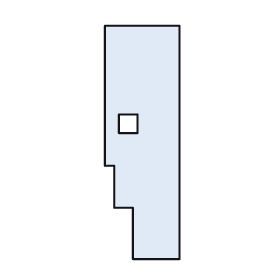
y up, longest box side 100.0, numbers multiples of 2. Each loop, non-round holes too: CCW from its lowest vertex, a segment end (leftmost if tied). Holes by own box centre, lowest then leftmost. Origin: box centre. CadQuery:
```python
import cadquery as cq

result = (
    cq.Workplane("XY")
    .moveTo(-4.0, -50.0)
    .lineTo(16.0, -50.0)
    .lineTo(16.0, 50.0)
    .lineTo(-16.0, 50.0)
    .lineTo(-16.0, -10.0)
    .lineTo(-12.0, -10.0)
    .lineTo(-12.0, -28.0)
    .lineTo(-4.0, -28.0)
    .close()
    .moveTo(-10.0, 4.0)
    .lineTo(-2.0, 4.0)
    .lineTo(-2.0, 12.0)
    .lineTo(-10.0, 12.0)
    .close()
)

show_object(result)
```